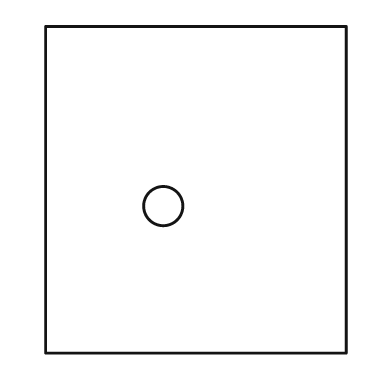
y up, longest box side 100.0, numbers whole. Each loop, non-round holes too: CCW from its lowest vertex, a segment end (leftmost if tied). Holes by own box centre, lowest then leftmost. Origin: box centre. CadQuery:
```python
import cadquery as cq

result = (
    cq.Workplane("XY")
    .moveTo(-46.0, -50.0)
    .lineTo(46.0, -50.0)
    .lineTo(46.0, 50.0)
    .lineTo(-46.0, 50.0)
    .close()
    .moveTo(-10.0, -5.0)
    .circle(6.0)
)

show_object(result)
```